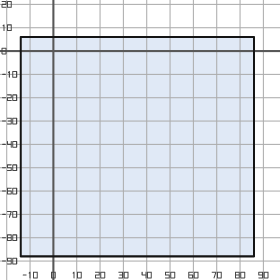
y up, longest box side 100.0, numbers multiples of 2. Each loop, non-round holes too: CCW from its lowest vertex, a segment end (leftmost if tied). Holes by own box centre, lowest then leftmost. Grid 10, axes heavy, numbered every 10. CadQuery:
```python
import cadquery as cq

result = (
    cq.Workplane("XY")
    .moveTo(-14.0, -88.0)
    .lineTo(86.0, -88.0)
    .lineTo(86.0, 6.0)
    .lineTo(-14.0, 6.0)
    .close()
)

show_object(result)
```